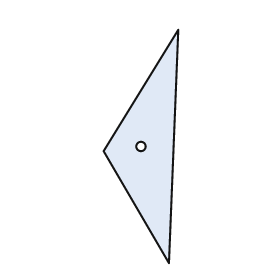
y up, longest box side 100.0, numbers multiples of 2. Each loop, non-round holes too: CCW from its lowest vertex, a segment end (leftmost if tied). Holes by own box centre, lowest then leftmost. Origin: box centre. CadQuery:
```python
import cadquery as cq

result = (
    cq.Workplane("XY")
    .moveTo(12.0, -50.0)
    .lineTo(16.0, 50.0)
    .lineTo(-16.0, -2.0)
    .close()
    .moveTo(0.0, 0.0)
    .circle(2.0)
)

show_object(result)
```